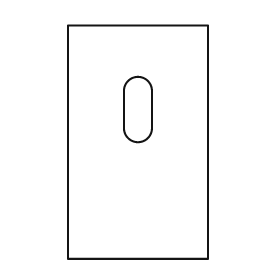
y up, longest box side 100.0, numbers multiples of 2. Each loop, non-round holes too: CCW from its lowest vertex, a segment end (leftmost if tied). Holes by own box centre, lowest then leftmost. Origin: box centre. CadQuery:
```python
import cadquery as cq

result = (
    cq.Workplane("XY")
    .moveTo(-30.0, -50.0)
    .lineTo(30.0, -50.0)
    .lineTo(30.0, 50.0)
    .lineTo(-30.0, 50.0)
    .close()
    .moveTo(-6.0, 6.0)
    .threePointArc((0.0, 0.0), (6.0, 6.0))
    .lineTo(6.0, 22.0)
    .threePointArc((0.0, 28.0), (-6.0, 22.0))
    .close()
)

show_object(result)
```